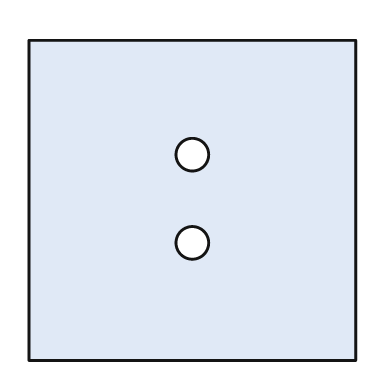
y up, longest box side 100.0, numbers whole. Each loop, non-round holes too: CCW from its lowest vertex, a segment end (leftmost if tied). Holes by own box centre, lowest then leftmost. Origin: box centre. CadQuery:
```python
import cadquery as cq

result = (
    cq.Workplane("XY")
    .moveTo(-50.0, -49.0)
    .lineTo(50.0, -49.0)
    .lineTo(50.0, 49.0)
    .lineTo(-50.0, 49.0)
    .close()
    .moveTo(0.0, -13.0)
    .circle(5.0)
    .moveTo(0.0, 14.0)
    .circle(5.0)
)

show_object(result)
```